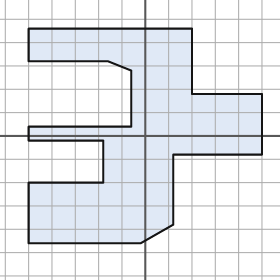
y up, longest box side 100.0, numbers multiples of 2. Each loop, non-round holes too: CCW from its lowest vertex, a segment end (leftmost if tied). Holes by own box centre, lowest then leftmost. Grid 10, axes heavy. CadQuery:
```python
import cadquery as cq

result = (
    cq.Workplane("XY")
    .moveTo(-50.0, -46.0)
    .lineTo(-2.0, -46.0)
    .lineTo(12.0, -38.0)
    .lineTo(12.0, -8.0)
    .lineTo(50.0, -8.0)
    .lineTo(50.0, 18.0)
    .lineTo(20.0, 18.0)
    .lineTo(20.0, 46.0)
    .lineTo(-50.0, 46.0)
    .lineTo(-50.0, 32.0)
    .lineTo(-16.0, 32.0)
    .lineTo(-6.0, 28.0)
    .lineTo(-6.0, 4.0)
    .lineTo(-50.0, 4.0)
    .lineTo(-50.0, -2.0)
    .lineTo(-18.0, -2.0)
    .lineTo(-18.0, -20.0)
    .lineTo(-50.0, -20.0)
    .close()
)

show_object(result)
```